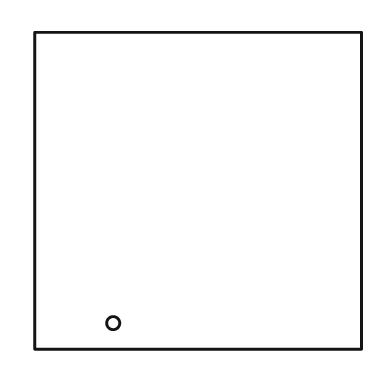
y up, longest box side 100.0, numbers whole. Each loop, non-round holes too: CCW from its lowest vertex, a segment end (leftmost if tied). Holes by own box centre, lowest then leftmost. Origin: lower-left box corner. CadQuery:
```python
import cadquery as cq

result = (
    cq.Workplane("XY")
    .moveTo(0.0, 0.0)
    .lineTo(100.0, 0.0)
    .lineTo(100.0, 97.0)
    .lineTo(0.0, 97.0)
    .close()
    .moveTo(24.0, 8.0)
    .circle(2.0)
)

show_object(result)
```